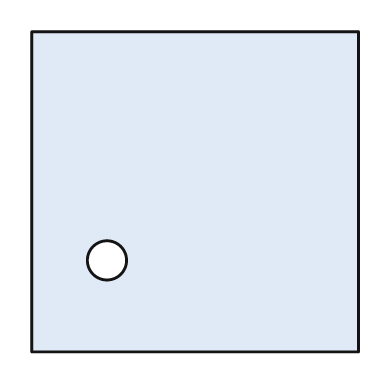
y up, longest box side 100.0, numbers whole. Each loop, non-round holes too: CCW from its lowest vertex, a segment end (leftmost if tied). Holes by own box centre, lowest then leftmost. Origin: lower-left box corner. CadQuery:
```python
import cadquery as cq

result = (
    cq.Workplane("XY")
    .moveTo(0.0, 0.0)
    .lineTo(100.0, 0.0)
    .lineTo(100.0, 98.0)
    .lineTo(0.0, 98.0)
    .close()
    .moveTo(23.0, 28.0)
    .circle(6.0)
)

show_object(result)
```